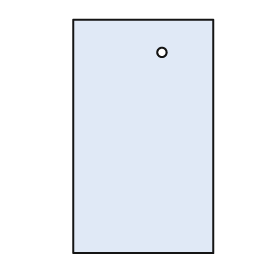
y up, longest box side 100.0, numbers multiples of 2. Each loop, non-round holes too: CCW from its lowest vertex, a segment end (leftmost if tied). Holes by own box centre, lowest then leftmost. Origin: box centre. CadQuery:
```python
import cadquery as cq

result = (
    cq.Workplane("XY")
    .moveTo(-30.0, -50.0)
    .lineTo(30.0, -50.0)
    .lineTo(30.0, 50.0)
    .lineTo(-30.0, 50.0)
    .close()
    .moveTo(8.0, 36.0)
    .circle(2.0)
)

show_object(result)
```